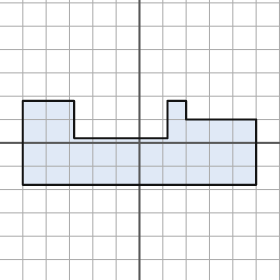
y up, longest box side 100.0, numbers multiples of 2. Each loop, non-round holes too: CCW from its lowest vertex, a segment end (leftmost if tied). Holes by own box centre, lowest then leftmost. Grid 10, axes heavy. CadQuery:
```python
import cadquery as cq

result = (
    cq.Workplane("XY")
    .moveTo(-50.0, -18.0)
    .lineTo(50.0, -18.0)
    .lineTo(50.0, 10.0)
    .lineTo(20.0, 10.0)
    .lineTo(20.0, 18.0)
    .lineTo(12.0, 18.0)
    .lineTo(12.0, 2.0)
    .lineTo(-28.0, 2.0)
    .lineTo(-28.0, 18.0)
    .lineTo(-50.0, 18.0)
    .close()
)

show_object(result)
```